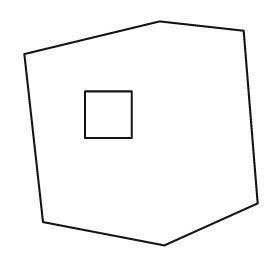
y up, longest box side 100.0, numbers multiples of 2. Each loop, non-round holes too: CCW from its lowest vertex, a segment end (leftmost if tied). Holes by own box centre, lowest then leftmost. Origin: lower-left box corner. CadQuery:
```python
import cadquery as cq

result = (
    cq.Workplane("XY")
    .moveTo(60.0, 0.0)
    .lineTo(100.0, 18.0)
    .lineTo(94.0, 92.0)
    .lineTo(58.0, 96.0)
    .lineTo(0.0, 82.0)
    .lineTo(8.0, 10.0)
    .close()
    .moveTo(26.0, 46.0)
    .lineTo(46.0, 46.0)
    .lineTo(46.0, 66.0)
    .lineTo(26.0, 66.0)
    .close()
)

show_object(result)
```